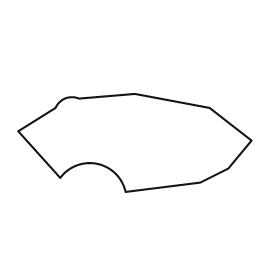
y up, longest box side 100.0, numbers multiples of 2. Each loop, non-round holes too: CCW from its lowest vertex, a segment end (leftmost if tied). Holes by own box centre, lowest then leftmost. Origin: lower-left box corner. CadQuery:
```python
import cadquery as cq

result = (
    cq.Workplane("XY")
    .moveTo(46.0, 0.0)
    .lineTo(78.0, 4.0)
    .lineTo(90.0, 10.0)
    .lineTo(100.0, 22.0)
    .lineTo(82.0, 36.0)
    .lineTo(50.0, 42.0)
    .lineTo(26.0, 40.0)
    .threePointArc((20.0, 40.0), (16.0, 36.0))
    .lineTo(0.0, 26.0)
    .lineTo(18.0, 6.0)
    .threePointArc((34.0, 12.0), (46.0, 0.0))
    .close()
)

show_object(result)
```